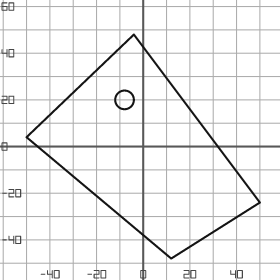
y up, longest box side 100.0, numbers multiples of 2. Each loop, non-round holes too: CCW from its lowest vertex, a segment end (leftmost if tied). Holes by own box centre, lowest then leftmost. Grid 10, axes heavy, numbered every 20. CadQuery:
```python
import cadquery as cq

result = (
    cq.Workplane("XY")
    .moveTo(12.0, -48.0)
    .lineTo(50.0, -24.0)
    .lineTo(-4.0, 48.0)
    .lineTo(-50.0, 4.0)
    .close()
    .moveTo(-8.0, 20.0)
    .circle(4.0)
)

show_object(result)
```